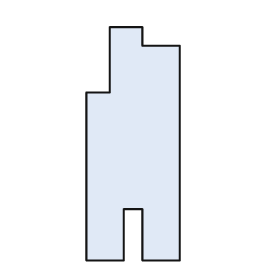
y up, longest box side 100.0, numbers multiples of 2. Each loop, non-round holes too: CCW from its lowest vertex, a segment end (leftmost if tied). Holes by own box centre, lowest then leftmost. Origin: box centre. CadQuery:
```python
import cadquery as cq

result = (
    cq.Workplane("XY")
    .moveTo(-20.0, -50.0)
    .lineTo(-4.0, -50.0)
    .lineTo(-4.0, -28.0)
    .lineTo(4.0, -28.0)
    .lineTo(4.0, -50.0)
    .lineTo(20.0, -50.0)
    .lineTo(20.0, 42.0)
    .lineTo(4.0, 42.0)
    .lineTo(4.0, 50.0)
    .lineTo(-10.0, 50.0)
    .lineTo(-10.0, 22.0)
    .lineTo(-20.0, 22.0)
    .close()
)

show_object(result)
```